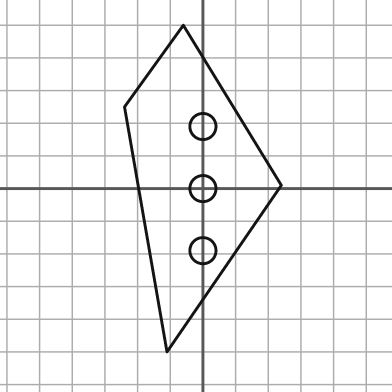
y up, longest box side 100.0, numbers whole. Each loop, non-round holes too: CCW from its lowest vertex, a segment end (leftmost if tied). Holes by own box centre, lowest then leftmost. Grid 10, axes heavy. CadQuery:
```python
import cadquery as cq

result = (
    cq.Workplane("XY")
    .moveTo(-11.0, -50.0)
    .lineTo(24.0, 1.0)
    .lineTo(-6.0, 50.0)
    .lineTo(-24.0, 25.0)
    .close()
    .moveTo(0.0, -19.0)
    .circle(4.0)
    .moveTo(0.0, 0.0)
    .circle(4.0)
    .moveTo(0.0, 19.0)
    .circle(4.0)
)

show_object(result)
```